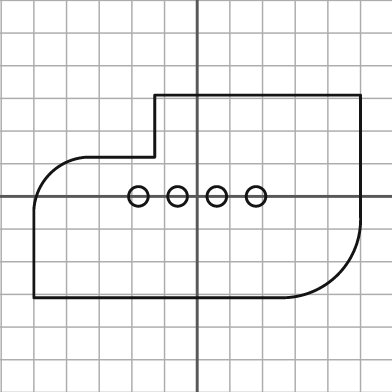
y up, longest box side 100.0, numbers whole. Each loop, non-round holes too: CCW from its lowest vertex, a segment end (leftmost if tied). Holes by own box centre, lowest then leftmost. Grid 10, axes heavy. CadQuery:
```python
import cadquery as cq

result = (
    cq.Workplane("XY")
    .moveTo(-50.0, -31.0)
    .lineTo(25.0, -31.0)
    .threePointArc((43.0, -24.0), (50.0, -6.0))
    .lineTo(50.0, 31.0)
    .lineTo(-13.0, 31.0)
    .lineTo(-13.0, 12.0)
    .lineTo(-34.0, 12.0)
    .threePointArc((-45.0, 7.0), (-50.0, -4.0))
    .close()
    .moveTo(-18.0, 0.0)
    .circle(3.0)
    .moveTo(-6.0, 0.0)
    .circle(3.0)
    .moveTo(6.0, 0.0)
    .circle(3.0)
    .moveTo(18.0, 0.0)
    .circle(3.0)
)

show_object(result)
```